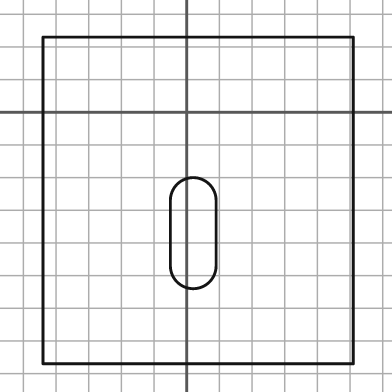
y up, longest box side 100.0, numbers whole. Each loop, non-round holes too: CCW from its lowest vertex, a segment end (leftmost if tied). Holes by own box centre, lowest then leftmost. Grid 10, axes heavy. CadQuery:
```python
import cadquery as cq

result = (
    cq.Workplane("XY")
    .moveTo(-44.0, -77.0)
    .lineTo(51.0, -77.0)
    .lineTo(51.0, 23.0)
    .lineTo(-44.0, 23.0)
    .close()
    .moveTo(-5.0, -47.0)
    .threePointArc((2.0, -54.0), (9.0, -47.0))
    .lineTo(9.0, -27.0)
    .threePointArc((2.0, -20.0), (-5.0, -27.0))
    .close()
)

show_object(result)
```